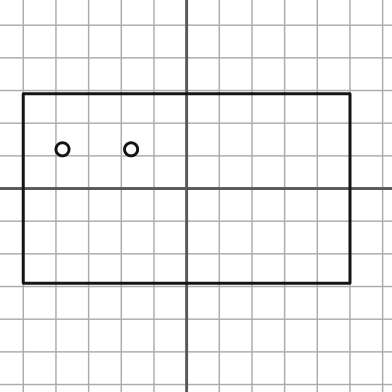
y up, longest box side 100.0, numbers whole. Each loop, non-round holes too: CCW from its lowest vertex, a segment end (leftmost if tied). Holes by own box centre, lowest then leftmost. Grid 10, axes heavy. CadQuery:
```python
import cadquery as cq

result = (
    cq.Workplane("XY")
    .moveTo(-50.0, -29.0)
    .lineTo(50.0, -29.0)
    .lineTo(50.0, 29.0)
    .lineTo(-50.0, 29.0)
    .close()
    .moveTo(-38.0, 12.0)
    .circle(2.0)
    .moveTo(-17.0, 12.0)
    .circle(2.0)
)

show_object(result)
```